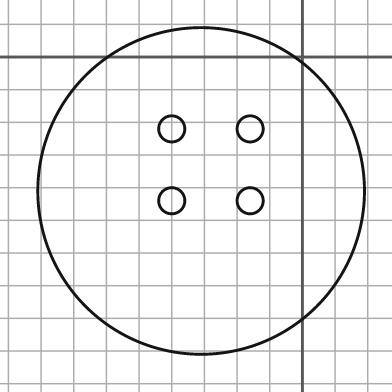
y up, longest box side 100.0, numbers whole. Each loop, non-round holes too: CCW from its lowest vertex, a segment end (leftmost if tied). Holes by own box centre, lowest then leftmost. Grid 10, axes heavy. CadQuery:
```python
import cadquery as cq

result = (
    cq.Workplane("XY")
    .moveTo(-31.0, -41.0)
    .circle(50.0)
    .moveTo(-40.0, -44.0)
    .circle(4.0)
    .moveTo(-16.0, -44.0)
    .circle(4.0)
    .moveTo(-40.0, -22.0)
    .circle(4.0)
    .moveTo(-16.0, -22.0)
    .circle(4.0)
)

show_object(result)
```